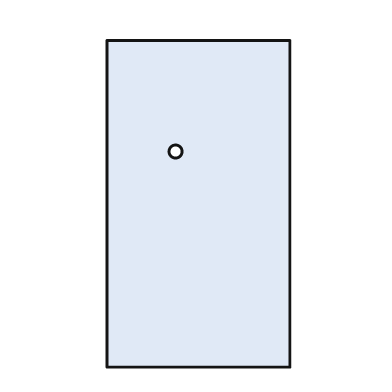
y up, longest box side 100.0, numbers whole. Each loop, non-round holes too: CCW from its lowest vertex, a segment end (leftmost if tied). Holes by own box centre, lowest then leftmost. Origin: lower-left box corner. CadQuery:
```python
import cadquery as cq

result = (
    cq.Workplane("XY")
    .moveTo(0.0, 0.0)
    .lineTo(56.0, 0.0)
    .lineTo(56.0, 100.0)
    .lineTo(0.0, 100.0)
    .close()
    .moveTo(21.0, 66.0)
    .circle(2.0)
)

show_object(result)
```